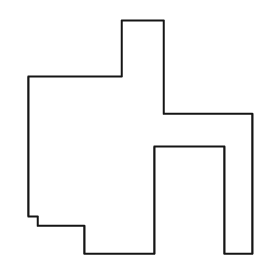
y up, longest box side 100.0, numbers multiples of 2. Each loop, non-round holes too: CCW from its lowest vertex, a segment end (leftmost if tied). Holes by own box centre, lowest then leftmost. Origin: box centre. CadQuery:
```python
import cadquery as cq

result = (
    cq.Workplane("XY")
    .moveTo(-24.0, -50.0)
    .lineTo(6.0, -50.0)
    .lineTo(6.0, -4.0)
    .lineTo(36.0, -4.0)
    .lineTo(36.0, -50.0)
    .lineTo(48.0, -50.0)
    .lineTo(48.0, 10.0)
    .lineTo(10.0, 10.0)
    .lineTo(10.0, 50.0)
    .lineTo(-8.0, 50.0)
    .lineTo(-8.0, 26.0)
    .lineTo(-48.0, 26.0)
    .lineTo(-48.0, -34.0)
    .lineTo(-44.0, -34.0)
    .lineTo(-44.0, -38.0)
    .lineTo(-24.0, -38.0)
    .close()
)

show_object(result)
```